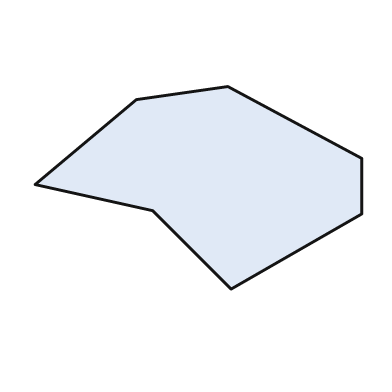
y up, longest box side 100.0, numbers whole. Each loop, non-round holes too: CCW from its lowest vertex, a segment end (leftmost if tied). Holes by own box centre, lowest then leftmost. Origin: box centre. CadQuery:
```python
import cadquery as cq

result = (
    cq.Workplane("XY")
    .moveTo(10.0, -31.0)
    .lineTo(50.0, -8.0)
    .lineTo(50.0, 9.0)
    .lineTo(9.0, 31.0)
    .lineTo(-19.0, 27.0)
    .lineTo(-50.0, 1.0)
    .lineTo(-14.0, -7.0)
    .close()
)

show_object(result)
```